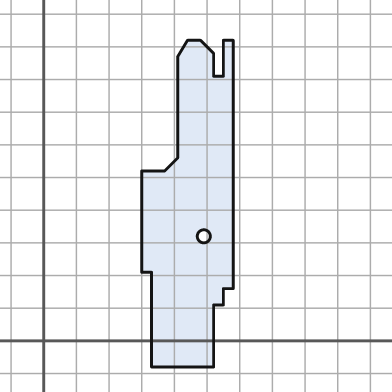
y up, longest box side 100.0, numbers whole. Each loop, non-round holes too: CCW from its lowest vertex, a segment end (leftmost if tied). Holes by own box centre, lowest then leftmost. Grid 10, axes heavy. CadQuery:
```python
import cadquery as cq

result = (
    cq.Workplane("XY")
    .moveTo(33.0, -8.0)
    .lineTo(52.0, -8.0)
    .lineTo(52.0, 11.0)
    .lineTo(55.0, 11.0)
    .lineTo(55.0, 16.0)
    .lineTo(58.0, 16.0)
    .lineTo(58.0, 92.0)
    .lineTo(55.0, 92.0)
    .lineTo(55.0, 81.0)
    .lineTo(52.0, 81.0)
    .lineTo(52.0, 88.0)
    .lineTo(48.0, 92.0)
    .lineTo(44.0, 92.0)
    .lineTo(41.0, 87.0)
    .lineTo(41.0, 56.0)
    .lineTo(37.0, 52.0)
    .lineTo(30.0, 52.0)
    .lineTo(30.0, 21.0)
    .lineTo(33.0, 21.0)
    .close()
    .moveTo(49.0, 32.0)
    .circle(2.0)
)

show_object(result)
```